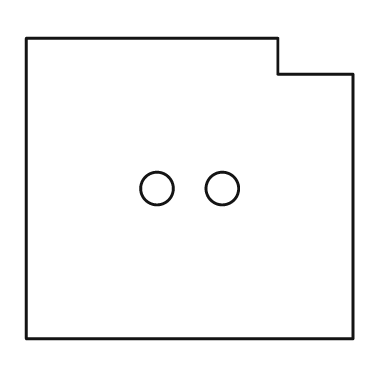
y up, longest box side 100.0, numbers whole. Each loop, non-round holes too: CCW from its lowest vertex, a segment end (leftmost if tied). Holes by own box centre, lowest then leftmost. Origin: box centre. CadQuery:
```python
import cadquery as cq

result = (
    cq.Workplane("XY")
    .moveTo(-50.0, -46.0)
    .lineTo(50.0, -46.0)
    .lineTo(50.0, 35.0)
    .lineTo(27.0, 35.0)
    .lineTo(27.0, 46.0)
    .lineTo(-50.0, 46.0)
    .close()
    .moveTo(-10.0, 0.0)
    .circle(5.0)
    .moveTo(10.0, 0.0)
    .circle(5.0)
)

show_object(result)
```